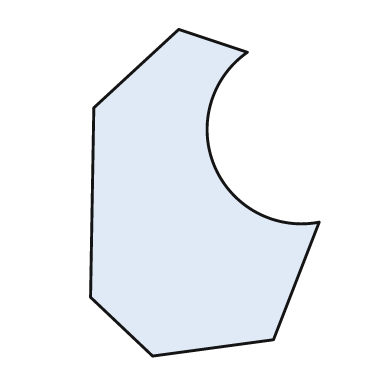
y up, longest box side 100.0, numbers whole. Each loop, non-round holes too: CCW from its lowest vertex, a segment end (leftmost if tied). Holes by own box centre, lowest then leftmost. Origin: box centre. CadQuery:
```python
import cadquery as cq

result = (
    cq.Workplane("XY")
    .moveTo(-16.0, -50.0)
    .lineTo(21.0, -45.0)
    .lineTo(35.0, -9.0)
    .threePointArc((3.0, 8.0), (13.0, 43.0))
    .lineTo(-8.0, 50.0)
    .lineTo(-34.0, 26.0)
    .lineTo(-35.0, -32.0)
    .close()
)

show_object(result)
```